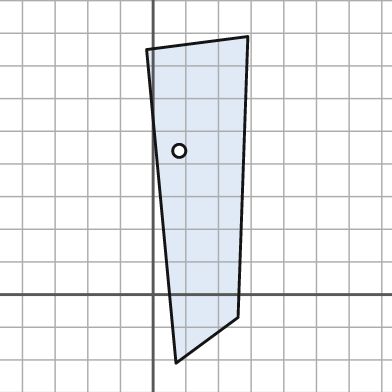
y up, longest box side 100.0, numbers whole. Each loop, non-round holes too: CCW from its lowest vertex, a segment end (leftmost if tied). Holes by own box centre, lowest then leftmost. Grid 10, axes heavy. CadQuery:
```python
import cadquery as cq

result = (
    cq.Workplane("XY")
    .moveTo(7.0, -21.0)
    .lineTo(26.0, -7.0)
    .lineTo(29.0, 79.0)
    .lineTo(-2.0, 75.0)
    .close()
    .moveTo(8.0, 44.0)
    .circle(2.0)
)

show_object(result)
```